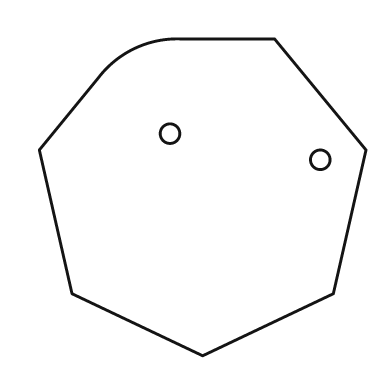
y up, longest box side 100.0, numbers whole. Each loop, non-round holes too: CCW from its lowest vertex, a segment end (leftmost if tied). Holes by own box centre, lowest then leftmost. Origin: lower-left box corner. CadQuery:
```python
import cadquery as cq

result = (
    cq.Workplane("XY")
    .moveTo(50.0, 0.0)
    .lineTo(90.0, 19.0)
    .lineTo(100.0, 63.0)
    .lineTo(72.0, 97.0)
    .lineTo(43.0, 97.0)
    .threePointArc((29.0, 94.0), (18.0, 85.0))
    .lineTo(0.0, 63.0)
    .lineTo(10.0, 19.0)
    .close()
    .moveTo(86.0, 60.0)
    .circle(3.0)
    .moveTo(40.0, 68.0)
    .circle(3.0)
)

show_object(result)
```